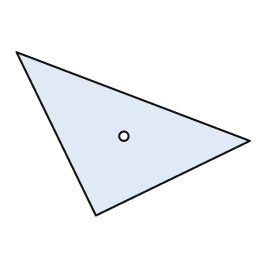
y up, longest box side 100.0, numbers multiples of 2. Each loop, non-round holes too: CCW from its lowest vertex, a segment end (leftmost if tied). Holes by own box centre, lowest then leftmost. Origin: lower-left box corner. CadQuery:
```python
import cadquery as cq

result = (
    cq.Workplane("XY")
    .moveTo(34.0, 0.0)
    .lineTo(100.0, 32.0)
    .lineTo(0.0, 70.0)
    .close()
    .moveTo(46.0, 34.0)
    .circle(2.0)
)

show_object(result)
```